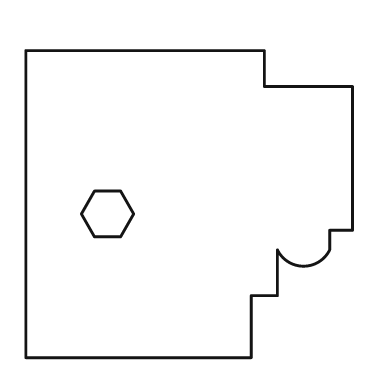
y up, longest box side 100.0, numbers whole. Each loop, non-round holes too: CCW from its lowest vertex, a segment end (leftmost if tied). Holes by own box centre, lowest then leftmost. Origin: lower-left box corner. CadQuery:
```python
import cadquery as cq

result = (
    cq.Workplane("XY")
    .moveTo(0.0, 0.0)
    .lineTo(69.0, 0.0)
    .lineTo(69.0, 19.0)
    .lineTo(77.0, 19.0)
    .lineTo(77.0, 33.0)
    .threePointArc((85.0, 28.0), (93.0, 33.0))
    .lineTo(93.0, 39.0)
    .lineTo(100.0, 39.0)
    .lineTo(100.0, 83.0)
    .lineTo(73.0, 83.0)
    .lineTo(73.0, 94.0)
    .lineTo(0.0, 94.0)
    .close()
    .moveTo(21.0, 37.0)
    .lineTo(29.0, 37.0)
    .lineTo(33.0, 44.0)
    .lineTo(29.0, 51.0)
    .lineTo(21.0, 51.0)
    .lineTo(17.0, 44.0)
    .close()
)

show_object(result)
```